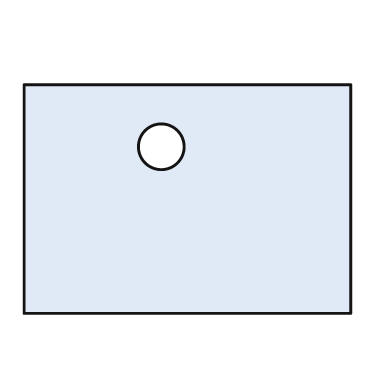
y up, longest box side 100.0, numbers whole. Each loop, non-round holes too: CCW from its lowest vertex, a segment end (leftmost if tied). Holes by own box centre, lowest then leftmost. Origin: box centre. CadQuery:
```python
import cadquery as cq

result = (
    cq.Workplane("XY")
    .moveTo(-50.0, -35.0)
    .lineTo(50.0, -35.0)
    .lineTo(50.0, 35.0)
    .lineTo(-50.0, 35.0)
    .close()
    .moveTo(-8.0, 16.0)
    .circle(7.0)
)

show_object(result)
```